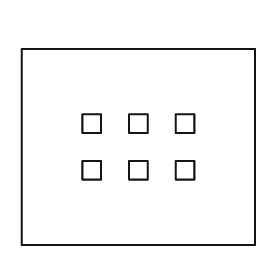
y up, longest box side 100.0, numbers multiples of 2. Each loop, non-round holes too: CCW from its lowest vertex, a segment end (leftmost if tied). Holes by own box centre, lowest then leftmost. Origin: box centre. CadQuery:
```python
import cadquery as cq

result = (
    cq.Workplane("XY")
    .moveTo(-50.0, -42.0)
    .lineTo(50.0, -42.0)
    .lineTo(50.0, 42.0)
    .lineTo(-50.0, 42.0)
    .close()
    .moveTo(-24.0, -14.0)
    .lineTo(-16.0, -14.0)
    .lineTo(-16.0, -6.0)
    .lineTo(-24.0, -6.0)
    .close()
    .moveTo(-4.0, -14.0)
    .lineTo(4.0, -14.0)
    .lineTo(4.0, -6.0)
    .lineTo(-4.0, -6.0)
    .close()
    .moveTo(16.0, -14.0)
    .lineTo(24.0, -14.0)
    .lineTo(24.0, -6.0)
    .lineTo(16.0, -6.0)
    .close()
    .moveTo(-24.0, 6.0)
    .lineTo(-16.0, 6.0)
    .lineTo(-16.0, 14.0)
    .lineTo(-24.0, 14.0)
    .close()
    .moveTo(-4.0, 6.0)
    .lineTo(4.0, 6.0)
    .lineTo(4.0, 14.0)
    .lineTo(-4.0, 14.0)
    .close()
    .moveTo(16.0, 6.0)
    .lineTo(24.0, 6.0)
    .lineTo(24.0, 14.0)
    .lineTo(16.0, 14.0)
    .close()
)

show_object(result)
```